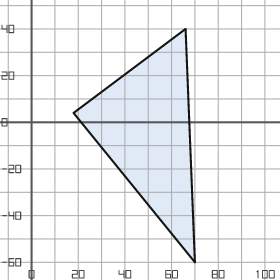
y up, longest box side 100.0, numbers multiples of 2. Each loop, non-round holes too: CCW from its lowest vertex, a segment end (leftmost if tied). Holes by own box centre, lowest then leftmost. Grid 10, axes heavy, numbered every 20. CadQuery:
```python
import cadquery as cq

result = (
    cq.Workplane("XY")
    .moveTo(70.0, -60.0)
    .lineTo(66.0, 40.0)
    .lineTo(18.0, 4.0)
    .close()
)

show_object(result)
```